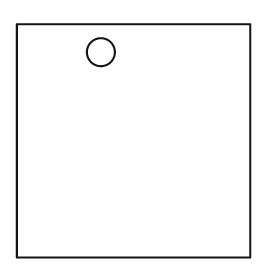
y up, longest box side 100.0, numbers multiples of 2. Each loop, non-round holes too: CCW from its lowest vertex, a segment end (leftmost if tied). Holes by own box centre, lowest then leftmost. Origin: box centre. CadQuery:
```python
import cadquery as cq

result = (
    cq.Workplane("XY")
    .moveTo(-50.0, -50.0)
    .lineTo(50.0, -50.0)
    .lineTo(50.0, 50.0)
    .lineTo(-50.0, 50.0)
    .close()
    .moveTo(-14.0, 38.0)
    .circle(6.0)
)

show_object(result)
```